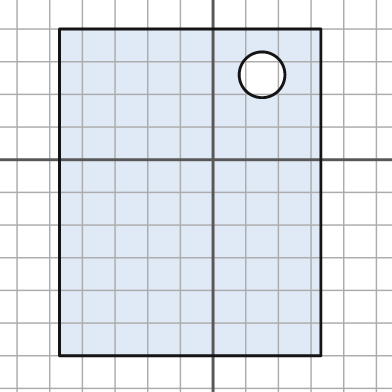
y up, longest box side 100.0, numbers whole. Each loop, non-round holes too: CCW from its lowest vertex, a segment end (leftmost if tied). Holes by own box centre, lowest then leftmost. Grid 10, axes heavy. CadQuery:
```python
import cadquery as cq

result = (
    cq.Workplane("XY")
    .moveTo(-47.0, -60.0)
    .lineTo(33.0, -60.0)
    .lineTo(33.0, 40.0)
    .lineTo(-47.0, 40.0)
    .close()
    .moveTo(15.0, 26.0)
    .circle(7.0)
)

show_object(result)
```